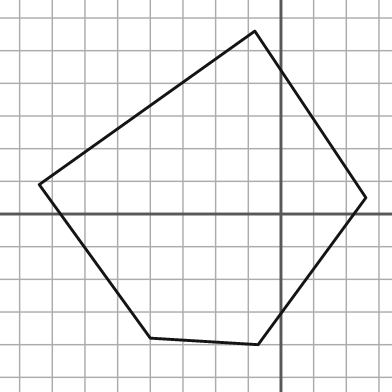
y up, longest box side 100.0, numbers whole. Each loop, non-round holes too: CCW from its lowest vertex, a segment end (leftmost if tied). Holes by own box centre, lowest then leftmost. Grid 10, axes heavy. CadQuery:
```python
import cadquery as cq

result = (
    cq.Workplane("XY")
    .moveTo(-7.0, -40.0)
    .lineTo(26.0, 5.0)
    .lineTo(-8.0, 56.0)
    .lineTo(-74.0, 9.0)
    .lineTo(-40.0, -38.0)
    .close()
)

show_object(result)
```